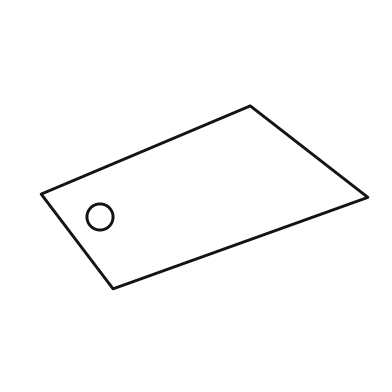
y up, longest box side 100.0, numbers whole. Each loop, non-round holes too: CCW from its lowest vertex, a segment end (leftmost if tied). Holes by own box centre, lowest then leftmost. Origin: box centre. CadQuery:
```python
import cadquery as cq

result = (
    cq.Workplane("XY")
    .moveTo(-28.0, -28.0)
    .lineTo(50.0, 0.0)
    .lineTo(14.0, 28.0)
    .lineTo(-50.0, 1.0)
    .close()
    .moveTo(-32.0, -6.0)
    .circle(4.0)
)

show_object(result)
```